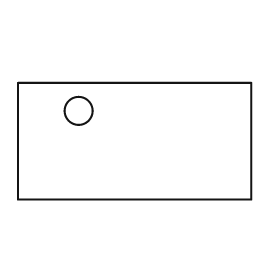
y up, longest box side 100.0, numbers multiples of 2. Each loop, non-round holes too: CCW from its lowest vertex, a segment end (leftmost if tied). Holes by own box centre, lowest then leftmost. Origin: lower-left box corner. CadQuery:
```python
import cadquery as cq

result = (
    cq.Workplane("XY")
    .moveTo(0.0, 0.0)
    .lineTo(100.0, 0.0)
    .lineTo(100.0, 50.0)
    .lineTo(0.0, 50.0)
    .close()
    .moveTo(26.0, 38.0)
    .circle(6.0)
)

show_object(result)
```